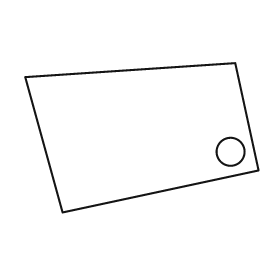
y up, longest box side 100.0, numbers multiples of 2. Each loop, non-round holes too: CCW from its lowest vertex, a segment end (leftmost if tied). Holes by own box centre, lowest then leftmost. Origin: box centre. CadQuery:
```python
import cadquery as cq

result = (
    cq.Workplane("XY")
    .moveTo(-34.0, -32.0)
    .lineTo(50.0, -14.0)
    .lineTo(40.0, 32.0)
    .lineTo(-50.0, 26.0)
    .close()
    .moveTo(38.0, -6.0)
    .circle(6.0)
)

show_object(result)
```